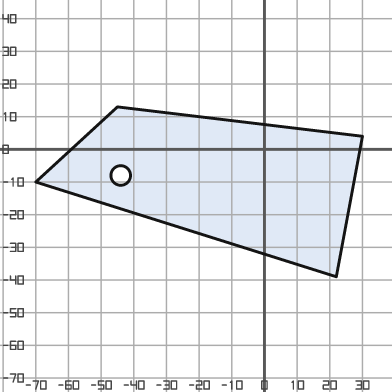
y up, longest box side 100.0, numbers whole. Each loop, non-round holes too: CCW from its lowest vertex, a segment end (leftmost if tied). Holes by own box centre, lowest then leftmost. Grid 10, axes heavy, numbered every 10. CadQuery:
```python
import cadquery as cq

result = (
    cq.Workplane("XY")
    .moveTo(22.0, -39.0)
    .lineTo(30.0, 4.0)
    .lineTo(-45.0, 13.0)
    .lineTo(-70.0, -10.0)
    .close()
    .moveTo(-44.0, -8.0)
    .circle(3.0)
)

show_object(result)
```